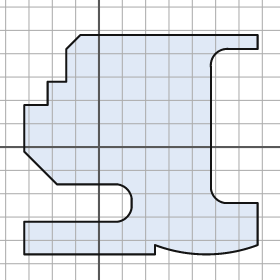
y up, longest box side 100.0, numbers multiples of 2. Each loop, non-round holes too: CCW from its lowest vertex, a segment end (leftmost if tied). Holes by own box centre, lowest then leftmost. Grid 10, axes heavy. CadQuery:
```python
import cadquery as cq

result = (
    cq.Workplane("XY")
    .moveTo(-32.0, -46.0)
    .lineTo(24.0, -46.0)
    .lineTo(24.0, -42.0)
    .threePointArc((46.0, -46.0), (68.0, -42.0))
    .lineTo(68.0, -24.0)
    .lineTo(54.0, -24.0)
    .threePointArc((50.0, -22.0), (48.0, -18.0))
    .lineTo(48.0, 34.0)
    .threePointArc((50.0, 40.0), (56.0, 42.0))
    .lineTo(68.0, 42.0)
    .lineTo(68.0, 48.0)
    .lineTo(-8.0, 48.0)
    .lineTo(-14.0, 42.0)
    .lineTo(-14.0, 28.0)
    .lineTo(-22.0, 28.0)
    .lineTo(-22.0, 18.0)
    .lineTo(-32.0, 18.0)
    .lineTo(-32.0, -2.0)
    .lineTo(-18.0, -16.0)
    .lineTo(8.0, -16.0)
    .threePointArc((12.0, -18.0), (14.0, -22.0))
    .lineTo(14.0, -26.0)
    .threePointArc((12.0, -30.0), (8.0, -32.0))
    .lineTo(-32.0, -32.0)
    .close()
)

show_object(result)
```